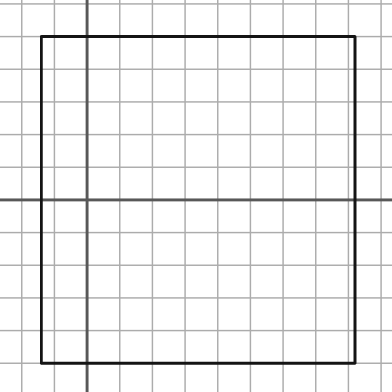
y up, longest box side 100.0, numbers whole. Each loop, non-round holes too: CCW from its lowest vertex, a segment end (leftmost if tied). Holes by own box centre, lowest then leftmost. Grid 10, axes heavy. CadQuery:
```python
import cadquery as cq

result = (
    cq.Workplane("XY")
    .moveTo(-14.0, -50.0)
    .lineTo(82.0, -50.0)
    .lineTo(82.0, 50.0)
    .lineTo(-14.0, 50.0)
    .close()
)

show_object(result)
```